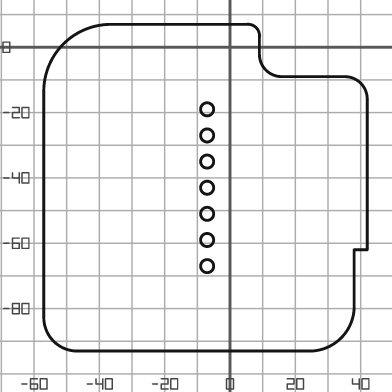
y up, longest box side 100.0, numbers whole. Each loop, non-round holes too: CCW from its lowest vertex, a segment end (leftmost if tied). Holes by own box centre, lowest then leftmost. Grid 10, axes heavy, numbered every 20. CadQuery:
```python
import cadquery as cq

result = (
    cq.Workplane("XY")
    .moveTo(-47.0, -93.0)
    .lineTo(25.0, -93.0)
    .threePointArc((34.0, -89.0), (38.0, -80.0))
    .lineTo(38.0, -62.0)
    .lineTo(42.0, -62.0)
    .lineTo(42.0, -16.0)
    .threePointArc((40.0, -11.0), (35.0, -9.0))
    .lineTo(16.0, -9.0)
    .threePointArc((11.0, -7.0), (9.0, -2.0))
    .lineTo(9.0, 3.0)
    .threePointArc((8.0, 6.0), (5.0, 7.0))
    .lineTo(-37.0, 7.0)
    .threePointArc((-51.0, 1.0), (-57.0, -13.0))
    .lineTo(-57.0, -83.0)
    .threePointArc((-54.0, -90.0), (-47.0, -93.0))
    .close()
    .moveTo(-7.0, -67.0)
    .circle(2.0)
    .moveTo(-7.0, -59.0)
    .circle(2.0)
    .moveTo(-7.0, -51.0)
    .circle(2.0)
    .moveTo(-7.0, -43.0)
    .circle(2.0)
    .moveTo(-7.0, -35.0)
    .circle(2.0)
    .moveTo(-7.0, -27.0)
    .circle(2.0)
    .moveTo(-7.0, -19.0)
    .circle(2.0)
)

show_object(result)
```